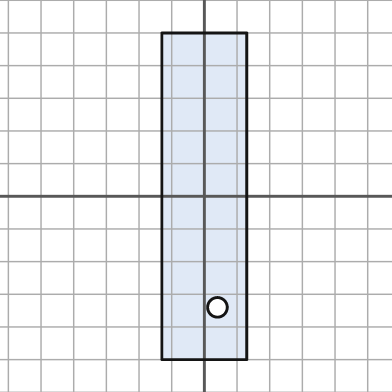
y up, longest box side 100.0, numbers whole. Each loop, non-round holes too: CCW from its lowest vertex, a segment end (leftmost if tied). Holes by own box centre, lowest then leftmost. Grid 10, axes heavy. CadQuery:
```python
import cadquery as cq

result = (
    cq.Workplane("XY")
    .moveTo(-13.0, -50.0)
    .lineTo(13.0, -50.0)
    .lineTo(13.0, 50.0)
    .lineTo(-13.0, 50.0)
    .close()
    .moveTo(4.0, -34.0)
    .circle(3.0)
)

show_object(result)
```